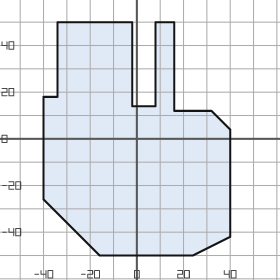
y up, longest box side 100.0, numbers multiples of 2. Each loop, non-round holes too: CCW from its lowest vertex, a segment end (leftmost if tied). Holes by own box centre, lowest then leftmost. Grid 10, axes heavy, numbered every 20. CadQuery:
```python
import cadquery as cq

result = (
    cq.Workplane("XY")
    .moveTo(-16.0, -50.0)
    .lineTo(24.0, -50.0)
    .lineTo(40.0, -42.0)
    .lineTo(40.0, 4.0)
    .lineTo(32.0, 12.0)
    .lineTo(16.0, 12.0)
    .lineTo(16.0, 50.0)
    .lineTo(8.0, 50.0)
    .lineTo(8.0, 14.0)
    .lineTo(-2.0, 14.0)
    .lineTo(-2.0, 50.0)
    .lineTo(-34.0, 50.0)
    .lineTo(-34.0, 18.0)
    .lineTo(-40.0, 18.0)
    .lineTo(-40.0, -26.0)
    .close()
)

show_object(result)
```